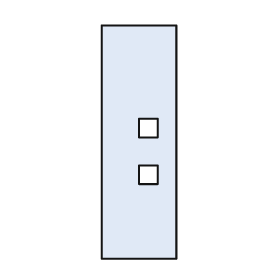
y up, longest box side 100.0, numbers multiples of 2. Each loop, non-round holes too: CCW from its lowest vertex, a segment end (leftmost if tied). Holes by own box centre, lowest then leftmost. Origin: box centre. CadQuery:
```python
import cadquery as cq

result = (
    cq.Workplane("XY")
    .moveTo(-16.0, -50.0)
    .lineTo(16.0, -50.0)
    .lineTo(16.0, 50.0)
    .lineTo(-16.0, 50.0)
    .close()
    .moveTo(0.0, -18.0)
    .lineTo(8.0, -18.0)
    .lineTo(8.0, -10.0)
    .lineTo(0.0, -10.0)
    .close()
    .moveTo(0.0, 2.0)
    .lineTo(8.0, 2.0)
    .lineTo(8.0, 10.0)
    .lineTo(0.0, 10.0)
    .close()
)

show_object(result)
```